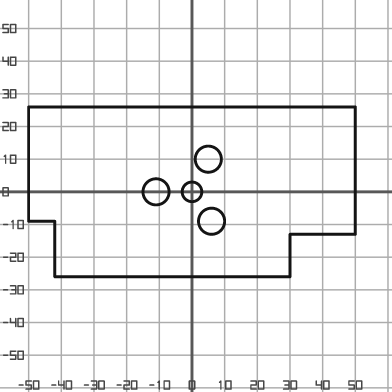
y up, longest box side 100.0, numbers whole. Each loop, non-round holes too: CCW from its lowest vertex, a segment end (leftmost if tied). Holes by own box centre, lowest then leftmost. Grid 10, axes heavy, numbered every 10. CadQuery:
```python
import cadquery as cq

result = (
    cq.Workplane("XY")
    .moveTo(-42.0, -26.0)
    .lineTo(30.0, -26.0)
    .lineTo(30.0, -13.0)
    .lineTo(50.0, -13.0)
    .lineTo(50.0, 26.0)
    .lineTo(-50.0, 26.0)
    .lineTo(-50.0, -9.0)
    .lineTo(-42.0, -9.0)
    .close()
    .moveTo(6.0, -9.0)
    .circle(4.0)
    .moveTo(-11.0, 0.0)
    .circle(4.0)
    .moveTo(0.0, 0.0)
    .circle(3.0)
    .moveTo(5.0, 10.0)
    .circle(4.0)
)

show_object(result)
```